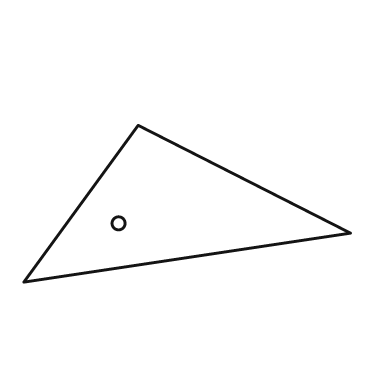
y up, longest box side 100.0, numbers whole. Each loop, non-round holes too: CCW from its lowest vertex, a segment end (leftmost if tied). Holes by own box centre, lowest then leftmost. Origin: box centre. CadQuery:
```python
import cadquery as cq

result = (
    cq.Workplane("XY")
    .moveTo(-50.0, -24.0)
    .lineTo(50.0, -9.0)
    .lineTo(-15.0, 24.0)
    .close()
    .moveTo(-21.0, -6.0)
    .circle(2.0)
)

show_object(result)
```